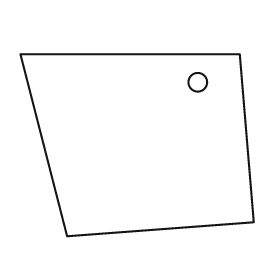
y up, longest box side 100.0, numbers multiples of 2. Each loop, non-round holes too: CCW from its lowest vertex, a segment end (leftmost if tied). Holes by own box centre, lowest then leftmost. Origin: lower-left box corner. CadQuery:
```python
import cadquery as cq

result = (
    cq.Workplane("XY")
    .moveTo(20.0, 0.0)
    .lineTo(100.0, 6.0)
    .lineTo(94.0, 78.0)
    .lineTo(0.0, 78.0)
    .close()
    .moveTo(76.0, 66.0)
    .circle(4.0)
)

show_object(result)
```